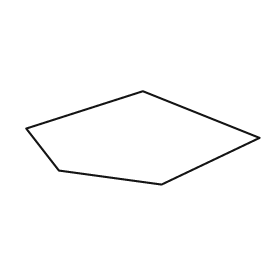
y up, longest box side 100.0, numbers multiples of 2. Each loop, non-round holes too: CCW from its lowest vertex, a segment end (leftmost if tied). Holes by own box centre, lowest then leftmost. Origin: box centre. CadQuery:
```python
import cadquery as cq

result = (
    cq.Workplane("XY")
    .moveTo(8.0, -20.0)
    .lineTo(50.0, 0.0)
    .lineTo(0.0, 20.0)
    .lineTo(-50.0, 4.0)
    .lineTo(-36.0, -14.0)
    .close()
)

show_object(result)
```